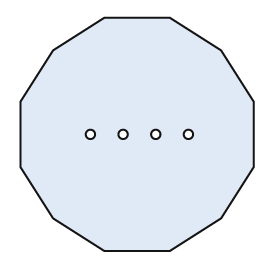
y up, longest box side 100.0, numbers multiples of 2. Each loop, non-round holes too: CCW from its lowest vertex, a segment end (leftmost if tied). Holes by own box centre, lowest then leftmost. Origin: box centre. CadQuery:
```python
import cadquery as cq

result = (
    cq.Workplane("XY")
    .moveTo(-14.0, -50.0)
    .lineTo(14.0, -50.0)
    .lineTo(36.0, -36.0)
    .lineTo(50.0, -14.0)
    .lineTo(50.0, 14.0)
    .lineTo(36.0, 36.0)
    .lineTo(14.0, 50.0)
    .lineTo(-14.0, 50.0)
    .lineTo(-36.0, 36.0)
    .lineTo(-50.0, 14.0)
    .lineTo(-50.0, -14.0)
    .lineTo(-36.0, -36.0)
    .close()
    .moveTo(-20.0, 0.0)
    .circle(2.0)
    .moveTo(-6.0, 0.0)
    .circle(2.0)
    .moveTo(8.0, 0.0)
    .circle(2.0)
    .moveTo(22.0, 0.0)
    .circle(2.0)
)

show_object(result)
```